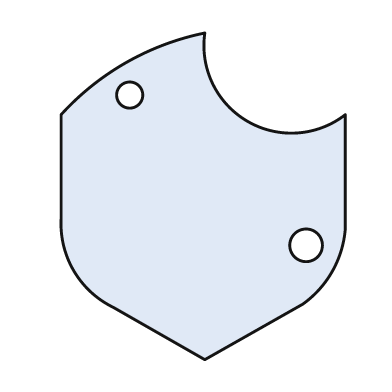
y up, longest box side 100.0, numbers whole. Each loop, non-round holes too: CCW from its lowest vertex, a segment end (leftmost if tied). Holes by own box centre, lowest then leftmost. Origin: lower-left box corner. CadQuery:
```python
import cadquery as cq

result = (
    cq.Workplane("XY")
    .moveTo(44.0, 0.0)
    .lineTo(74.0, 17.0)
    .threePointArc((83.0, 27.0), (87.0, 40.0))
    .lineTo(87.0, 75.0)
    .threePointArc((57.0, 73.0), (44.0, 100.0))
    .threePointArc((20.0, 91.0), (0.0, 75.0))
    .lineTo(0.0, 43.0)
    .threePointArc((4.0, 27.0), (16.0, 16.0))
    .close()
    .moveTo(75.0, 35.0)
    .circle(5.0)
    .moveTo(21.0, 81.0)
    .circle(4.0)
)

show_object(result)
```